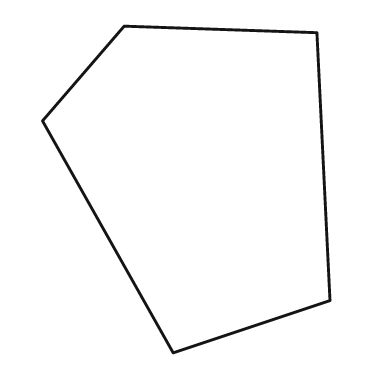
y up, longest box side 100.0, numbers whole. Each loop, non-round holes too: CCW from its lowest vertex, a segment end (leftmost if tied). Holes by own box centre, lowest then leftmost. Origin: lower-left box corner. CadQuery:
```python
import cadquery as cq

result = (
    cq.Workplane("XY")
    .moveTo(40.0, 0.0)
    .lineTo(88.0, 16.0)
    .lineTo(84.0, 98.0)
    .lineTo(25.0, 100.0)
    .lineTo(0.0, 71.0)
    .close()
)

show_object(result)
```